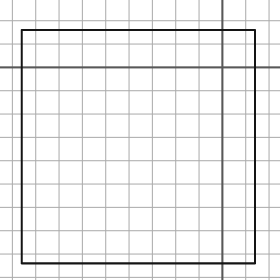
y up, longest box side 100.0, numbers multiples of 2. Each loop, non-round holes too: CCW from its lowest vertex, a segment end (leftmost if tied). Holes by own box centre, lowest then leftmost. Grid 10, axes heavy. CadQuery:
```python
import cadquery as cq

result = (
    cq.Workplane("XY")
    .moveTo(-86.0, -84.0)
    .lineTo(14.0, -84.0)
    .lineTo(14.0, 16.0)
    .lineTo(-86.0, 16.0)
    .close()
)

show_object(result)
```